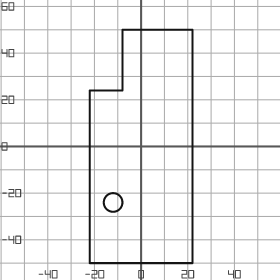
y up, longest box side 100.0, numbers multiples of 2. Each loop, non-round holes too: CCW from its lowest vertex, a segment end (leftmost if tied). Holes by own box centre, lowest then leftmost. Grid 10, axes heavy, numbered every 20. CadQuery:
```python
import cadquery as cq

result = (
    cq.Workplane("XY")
    .moveTo(-22.0, -50.0)
    .lineTo(22.0, -50.0)
    .lineTo(22.0, 50.0)
    .lineTo(-8.0, 50.0)
    .lineTo(-8.0, 24.0)
    .lineTo(-22.0, 24.0)
    .close()
    .moveTo(-12.0, -24.0)
    .circle(4.0)
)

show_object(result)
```